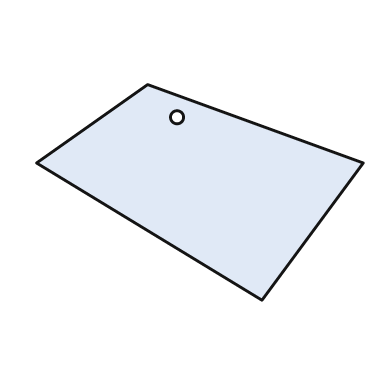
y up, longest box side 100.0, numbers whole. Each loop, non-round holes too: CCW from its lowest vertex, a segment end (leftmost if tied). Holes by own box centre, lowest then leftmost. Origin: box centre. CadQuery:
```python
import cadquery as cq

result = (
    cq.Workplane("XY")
    .moveTo(19.0, -33.0)
    .lineTo(50.0, 9.0)
    .lineTo(-16.0, 33.0)
    .lineTo(-50.0, 9.0)
    .close()
    .moveTo(-7.0, 23.0)
    .circle(2.0)
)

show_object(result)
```